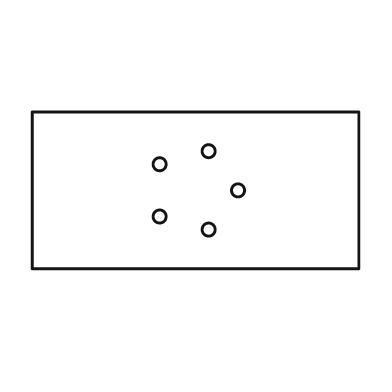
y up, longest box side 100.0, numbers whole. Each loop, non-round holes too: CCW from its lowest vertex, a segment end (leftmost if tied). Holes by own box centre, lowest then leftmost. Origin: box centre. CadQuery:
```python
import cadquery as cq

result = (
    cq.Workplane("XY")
    .moveTo(-50.0, -24.0)
    .lineTo(50.0, -24.0)
    .lineTo(50.0, 24.0)
    .lineTo(-50.0, 24.0)
    .close()
    .moveTo(4.0, -12.0)
    .circle(2.0)
    .moveTo(-11.0, -8.0)
    .circle(2.0)
    .moveTo(13.0, 0.0)
    .circle(2.0)
    .moveTo(-11.0, 8.0)
    .circle(2.0)
    .moveTo(4.0, 12.0)
    .circle(2.0)
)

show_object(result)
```